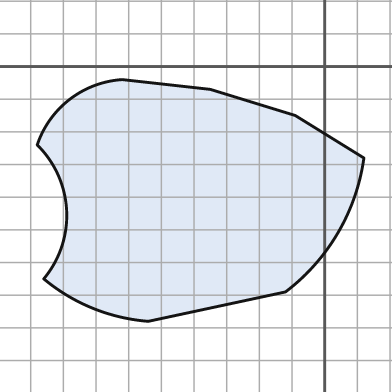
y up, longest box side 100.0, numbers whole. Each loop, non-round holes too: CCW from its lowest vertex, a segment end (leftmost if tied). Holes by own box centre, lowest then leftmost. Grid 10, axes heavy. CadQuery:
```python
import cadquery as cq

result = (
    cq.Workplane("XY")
    .moveTo(-54.0, -78.0)
    .lineTo(-12.0, -69.0)
    .threePointArc((4.0, -51.0), (12.0, -28.0))
    .lineTo(-9.0, -15.0)
    .lineTo(-35.0, -7.0)
    .lineTo(-62.0, -4.0)
    .threePointArc((-78.0, -10.0), (-88.0, -24.0))
    .threePointArc((-79.0, -44.0), (-86.0, -65.0))
    .threePointArc((-71.0, -74.0), (-54.0, -78.0))
    .close()
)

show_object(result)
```